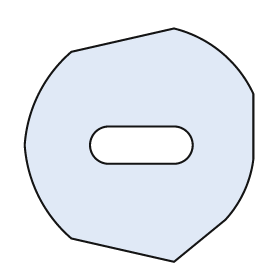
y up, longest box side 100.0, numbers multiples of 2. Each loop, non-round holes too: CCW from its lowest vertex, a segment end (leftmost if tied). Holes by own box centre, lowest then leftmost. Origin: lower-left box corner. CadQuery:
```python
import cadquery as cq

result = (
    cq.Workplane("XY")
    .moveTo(64.0, 0.0)
    .lineTo(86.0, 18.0)
    .threePointArc((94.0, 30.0), (98.0, 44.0))
    .lineTo(98.0, 72.0)
    .threePointArc((84.0, 90.0), (64.0, 100.0))
    .lineTo(20.0, 90.0)
    .threePointArc((6.0, 72.0), (0.0, 50.0))
    .threePointArc((6.0, 28.0), (20.0, 10.0))
    .close()
    .moveTo(36.0, 42.0)
    .lineTo(64.0, 42.0)
    .threePointArc((72.0, 50.0), (64.0, 58.0))
    .lineTo(36.0, 58.0)
    .threePointArc((28.0, 50.0), (36.0, 42.0))
    .close()
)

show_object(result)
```